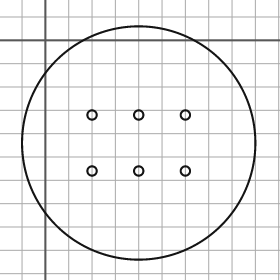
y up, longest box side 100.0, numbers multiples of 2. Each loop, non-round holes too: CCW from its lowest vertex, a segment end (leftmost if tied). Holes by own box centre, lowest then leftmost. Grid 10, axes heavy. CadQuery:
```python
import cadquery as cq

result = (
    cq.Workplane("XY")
    .moveTo(40.0, -44.0)
    .circle(50.0)
    .moveTo(20.0, -56.0)
    .circle(2.0)
    .moveTo(40.0, -56.0)
    .circle(2.0)
    .moveTo(60.0, -56.0)
    .circle(2.0)
    .moveTo(20.0, -32.0)
    .circle(2.0)
    .moveTo(40.0, -32.0)
    .circle(2.0)
    .moveTo(60.0, -32.0)
    .circle(2.0)
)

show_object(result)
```